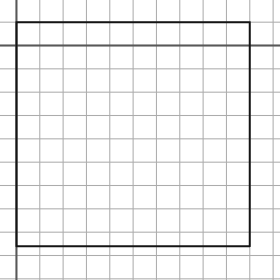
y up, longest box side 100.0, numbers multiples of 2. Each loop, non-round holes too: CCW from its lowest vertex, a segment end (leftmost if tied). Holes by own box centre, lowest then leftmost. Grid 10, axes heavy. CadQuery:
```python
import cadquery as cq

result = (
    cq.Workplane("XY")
    .moveTo(0.0, -86.0)
    .lineTo(100.0, -86.0)
    .lineTo(100.0, 10.0)
    .lineTo(0.0, 10.0)
    .close()
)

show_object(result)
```